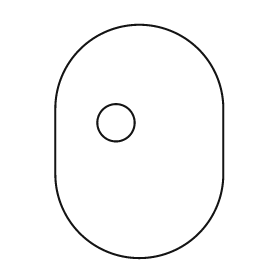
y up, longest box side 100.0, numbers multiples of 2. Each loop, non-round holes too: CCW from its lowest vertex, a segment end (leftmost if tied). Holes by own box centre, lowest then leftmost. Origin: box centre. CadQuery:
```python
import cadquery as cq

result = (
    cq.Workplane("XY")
    .moveTo(-36.0, -14.0)
    .threePointArc((0.0, -50.0), (36.0, -14.0))
    .lineTo(36.0, 14.0)
    .threePointArc((0.0, 50.0), (-36.0, 14.0))
    .close()
    .moveTo(-10.0, 8.0)
    .circle(8.0)
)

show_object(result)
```